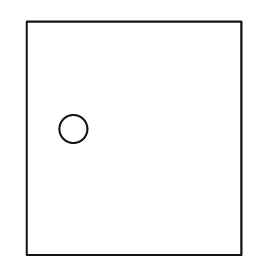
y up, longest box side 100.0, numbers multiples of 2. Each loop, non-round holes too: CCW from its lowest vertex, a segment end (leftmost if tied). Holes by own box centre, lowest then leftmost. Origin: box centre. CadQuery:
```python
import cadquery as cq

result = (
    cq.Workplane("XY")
    .moveTo(-46.0, -50.0)
    .lineTo(46.0, -50.0)
    .lineTo(46.0, 50.0)
    .lineTo(-46.0, 50.0)
    .close()
    .moveTo(-26.0, 4.0)
    .circle(6.0)
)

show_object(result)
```